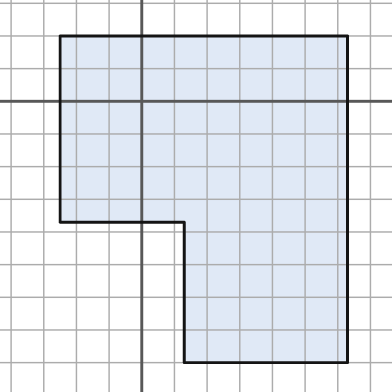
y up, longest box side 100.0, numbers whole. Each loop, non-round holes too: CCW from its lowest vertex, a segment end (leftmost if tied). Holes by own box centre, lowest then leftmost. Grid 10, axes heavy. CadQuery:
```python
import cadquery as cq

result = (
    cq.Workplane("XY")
    .moveTo(13.0, -80.0)
    .lineTo(63.0, -80.0)
    .lineTo(63.0, 20.0)
    .lineTo(-25.0, 20.0)
    .lineTo(-25.0, -37.0)
    .lineTo(13.0, -37.0)
    .close()
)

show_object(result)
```